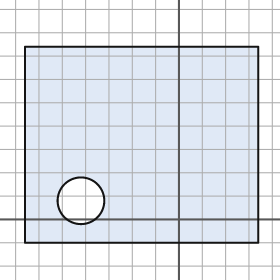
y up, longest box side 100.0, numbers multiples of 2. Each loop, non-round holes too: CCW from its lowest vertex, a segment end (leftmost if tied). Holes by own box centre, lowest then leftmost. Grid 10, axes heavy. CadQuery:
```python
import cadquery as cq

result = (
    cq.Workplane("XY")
    .moveTo(-66.0, -10.0)
    .lineTo(34.0, -10.0)
    .lineTo(34.0, 74.0)
    .lineTo(-66.0, 74.0)
    .close()
    .moveTo(-42.0, 8.0)
    .circle(10.0)
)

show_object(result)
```